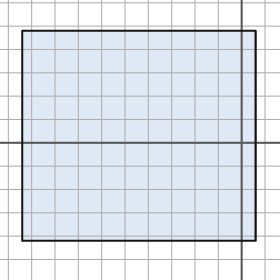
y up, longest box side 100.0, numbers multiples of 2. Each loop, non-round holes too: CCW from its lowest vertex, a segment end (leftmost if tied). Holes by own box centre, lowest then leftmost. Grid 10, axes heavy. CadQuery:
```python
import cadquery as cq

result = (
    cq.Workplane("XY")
    .moveTo(-94.0, -42.0)
    .lineTo(6.0, -42.0)
    .lineTo(6.0, 48.0)
    .lineTo(-94.0, 48.0)
    .close()
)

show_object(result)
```